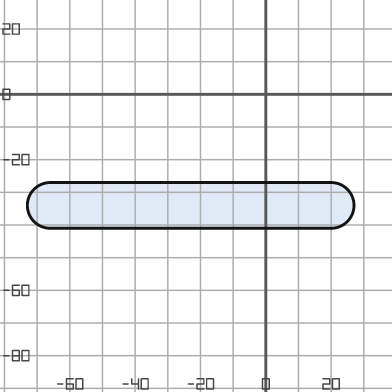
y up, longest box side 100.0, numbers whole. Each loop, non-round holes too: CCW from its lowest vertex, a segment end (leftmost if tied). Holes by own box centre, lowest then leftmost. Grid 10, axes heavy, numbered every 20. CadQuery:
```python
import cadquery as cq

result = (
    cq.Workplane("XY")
    .moveTo(-66.0, -41.0)
    .lineTo(20.0, -41.0)
    .threePointArc((27.0, -34.0), (20.0, -27.0))
    .lineTo(-66.0, -27.0)
    .threePointArc((-73.0, -34.0), (-66.0, -41.0))
    .close()
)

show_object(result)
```